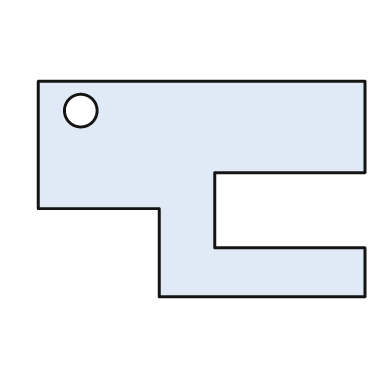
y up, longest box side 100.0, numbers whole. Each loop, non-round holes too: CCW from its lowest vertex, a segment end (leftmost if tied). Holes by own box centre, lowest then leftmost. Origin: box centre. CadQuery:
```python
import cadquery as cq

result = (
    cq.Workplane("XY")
    .moveTo(-13.0, -33.0)
    .lineTo(50.0, -33.0)
    .lineTo(50.0, -18.0)
    .lineTo(4.0, -18.0)
    .lineTo(4.0, 5.0)
    .lineTo(50.0, 5.0)
    .lineTo(50.0, 33.0)
    .lineTo(-50.0, 33.0)
    .lineTo(-50.0, -6.0)
    .lineTo(-13.0, -6.0)
    .close()
    .moveTo(-37.0, 24.0)
    .circle(5.0)
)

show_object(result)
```